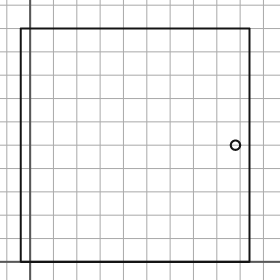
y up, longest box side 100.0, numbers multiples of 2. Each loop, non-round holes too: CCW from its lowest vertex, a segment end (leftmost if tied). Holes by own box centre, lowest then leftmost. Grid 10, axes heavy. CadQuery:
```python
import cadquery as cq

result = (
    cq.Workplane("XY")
    .moveTo(-4.0, 0.0)
    .lineTo(94.0, 0.0)
    .lineTo(94.0, 100.0)
    .lineTo(-4.0, 100.0)
    .close()
    .moveTo(88.0, 50.0)
    .circle(2.0)
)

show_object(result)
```